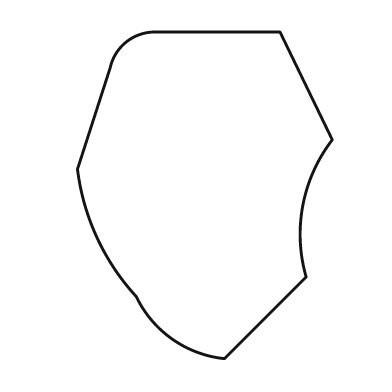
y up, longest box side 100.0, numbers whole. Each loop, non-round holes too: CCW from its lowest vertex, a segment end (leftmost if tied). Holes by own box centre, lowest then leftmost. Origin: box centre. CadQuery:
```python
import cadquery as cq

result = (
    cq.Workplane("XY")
    .moveTo(6.0, -50.0)
    .lineTo(31.0, -25.0)
    .threePointArc((30.0, -3.0), (39.0, 17.0))
    .lineTo(23.0, 50.0)
    .lineTo(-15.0, 50.0)
    .threePointArc((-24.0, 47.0), (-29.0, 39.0))
    .lineTo(-39.0, 8.0)
    .threePointArc((-33.0, -13.0), (-21.0, -31.0))
    .threePointArc((-10.0, -44.0), (6.0, -50.0))
    .close()
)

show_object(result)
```